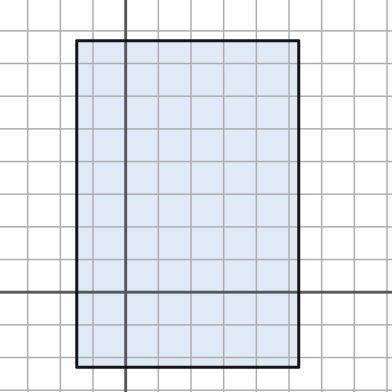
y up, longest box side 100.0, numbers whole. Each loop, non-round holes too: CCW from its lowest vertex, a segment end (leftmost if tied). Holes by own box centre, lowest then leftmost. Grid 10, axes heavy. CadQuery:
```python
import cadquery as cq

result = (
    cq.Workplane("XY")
    .moveTo(-15.0, -23.0)
    .lineTo(53.0, -23.0)
    .lineTo(53.0, 77.0)
    .lineTo(-15.0, 77.0)
    .close()
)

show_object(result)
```